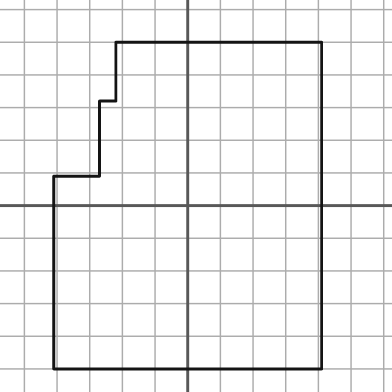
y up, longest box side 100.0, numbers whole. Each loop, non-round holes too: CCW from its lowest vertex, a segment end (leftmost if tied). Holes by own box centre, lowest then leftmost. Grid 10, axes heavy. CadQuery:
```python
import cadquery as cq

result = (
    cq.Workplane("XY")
    .moveTo(-41.0, -50.0)
    .lineTo(41.0, -50.0)
    .lineTo(41.0, 50.0)
    .lineTo(-22.0, 50.0)
    .lineTo(-22.0, 32.0)
    .lineTo(-27.0, 32.0)
    .lineTo(-27.0, 9.0)
    .lineTo(-41.0, 9.0)
    .close()
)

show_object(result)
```